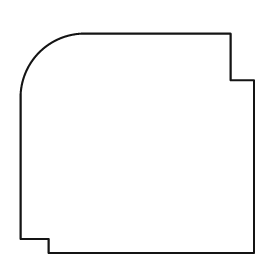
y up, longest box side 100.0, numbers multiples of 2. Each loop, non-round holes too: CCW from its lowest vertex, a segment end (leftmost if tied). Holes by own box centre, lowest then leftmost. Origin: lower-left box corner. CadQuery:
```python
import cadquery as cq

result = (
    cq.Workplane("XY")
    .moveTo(12.0, 0.0)
    .lineTo(100.0, 0.0)
    .lineTo(100.0, 74.0)
    .lineTo(90.0, 74.0)
    .lineTo(90.0, 94.0)
    .lineTo(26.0, 94.0)
    .threePointArc((8.0, 86.0), (0.0, 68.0))
    .lineTo(0.0, 6.0)
    .lineTo(12.0, 6.0)
    .close()
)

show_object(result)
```